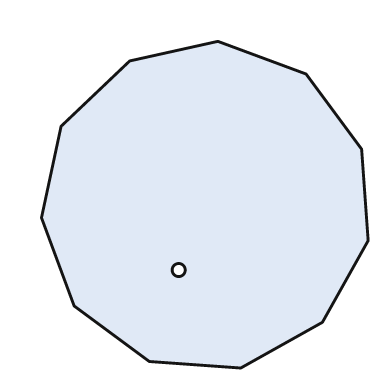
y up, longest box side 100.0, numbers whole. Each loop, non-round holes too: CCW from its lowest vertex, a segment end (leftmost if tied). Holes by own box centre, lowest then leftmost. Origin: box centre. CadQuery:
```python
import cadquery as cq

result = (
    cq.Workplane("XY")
    .moveTo(11.0, -50.0)
    .lineTo(36.0, -36.0)
    .lineTo(50.0, -11.0)
    .lineTo(48.0, 17.0)
    .lineTo(31.0, 40.0)
    .lineTo(4.0, 50.0)
    .lineTo(-23.0, 44.0)
    .lineTo(-44.0, 24.0)
    .lineTo(-50.0, -4.0)
    .lineTo(-40.0, -31.0)
    .lineTo(-17.0, -48.0)
    .close()
    .moveTo(-8.0, -20.0)
    .circle(2.0)
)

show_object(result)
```